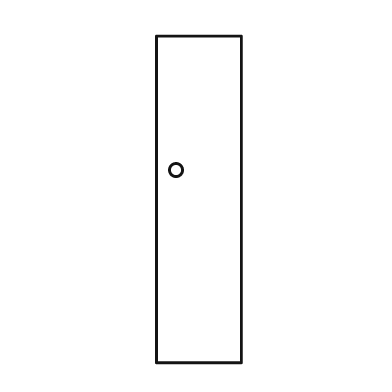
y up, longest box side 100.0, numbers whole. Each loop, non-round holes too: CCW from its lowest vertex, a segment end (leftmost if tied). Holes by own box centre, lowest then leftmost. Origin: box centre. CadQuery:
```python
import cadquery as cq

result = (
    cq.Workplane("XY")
    .moveTo(-13.0, -50.0)
    .lineTo(13.0, -50.0)
    .lineTo(13.0, 50.0)
    .lineTo(-13.0, 50.0)
    .close()
    .moveTo(-7.0, 9.0)
    .circle(2.0)
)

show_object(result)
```